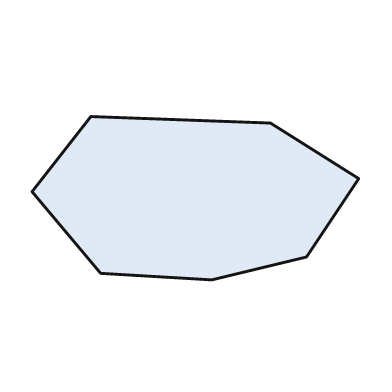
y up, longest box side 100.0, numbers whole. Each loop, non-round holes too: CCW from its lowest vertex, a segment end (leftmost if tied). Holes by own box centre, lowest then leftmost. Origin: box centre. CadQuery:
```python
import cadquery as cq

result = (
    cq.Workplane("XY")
    .moveTo(5.0, -25.0)
    .lineTo(34.0, -18.0)
    .lineTo(50.0, 6.0)
    .lineTo(23.0, 23.0)
    .lineTo(-32.0, 25.0)
    .lineTo(-50.0, 2.0)
    .lineTo(-29.0, -23.0)
    .close()
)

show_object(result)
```